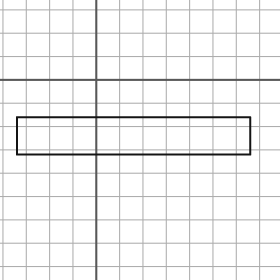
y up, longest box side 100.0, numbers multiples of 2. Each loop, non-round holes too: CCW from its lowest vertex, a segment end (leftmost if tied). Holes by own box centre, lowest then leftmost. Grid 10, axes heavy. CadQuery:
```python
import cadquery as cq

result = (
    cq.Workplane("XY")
    .moveTo(-34.0, -32.0)
    .lineTo(66.0, -32.0)
    .lineTo(66.0, -16.0)
    .lineTo(-34.0, -16.0)
    .close()
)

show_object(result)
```